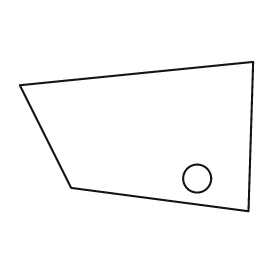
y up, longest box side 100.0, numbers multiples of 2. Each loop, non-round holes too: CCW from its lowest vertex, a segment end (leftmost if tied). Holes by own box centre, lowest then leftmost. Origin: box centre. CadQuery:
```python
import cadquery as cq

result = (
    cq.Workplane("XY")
    .moveTo(48.0, -32.0)
    .lineTo(50.0, 32.0)
    .lineTo(-50.0, 22.0)
    .lineTo(-28.0, -22.0)
    .close()
    .moveTo(26.0, -18.0)
    .circle(6.0)
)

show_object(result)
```